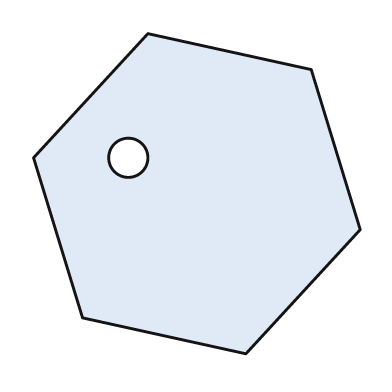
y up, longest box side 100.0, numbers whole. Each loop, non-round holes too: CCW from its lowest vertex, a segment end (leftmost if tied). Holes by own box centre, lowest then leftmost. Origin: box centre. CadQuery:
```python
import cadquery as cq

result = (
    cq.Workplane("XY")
    .moveTo(15.0, -49.0)
    .lineTo(50.0, -11.0)
    .lineTo(35.0, 38.0)
    .lineTo(-15.0, 49.0)
    .lineTo(-50.0, 11.0)
    .lineTo(-35.0, -38.0)
    .close()
    .moveTo(-21.0, 11.0)
    .circle(6.0)
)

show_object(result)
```